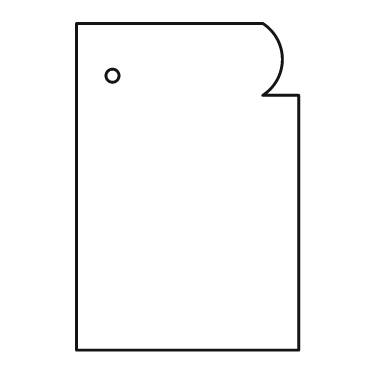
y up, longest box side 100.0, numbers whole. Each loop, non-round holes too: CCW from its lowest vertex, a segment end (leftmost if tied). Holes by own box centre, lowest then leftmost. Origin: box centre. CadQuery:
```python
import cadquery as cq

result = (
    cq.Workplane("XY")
    .moveTo(-34.0, -50.0)
    .lineTo(34.0, -50.0)
    .lineTo(34.0, 28.0)
    .lineTo(23.0, 28.0)
    .threePointArc((29.0, 39.0), (23.0, 50.0))
    .lineTo(-34.0, 50.0)
    .close()
    .moveTo(-23.0, 34.0)
    .circle(2.0)
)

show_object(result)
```